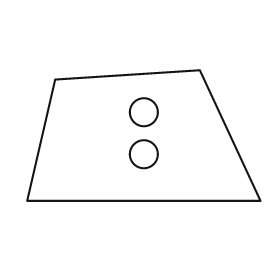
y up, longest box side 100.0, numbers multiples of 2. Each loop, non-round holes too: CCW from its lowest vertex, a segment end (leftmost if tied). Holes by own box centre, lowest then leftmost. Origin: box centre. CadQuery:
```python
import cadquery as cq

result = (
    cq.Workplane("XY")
    .moveTo(-50.0, -28.0)
    .lineTo(50.0, -28.0)
    .lineTo(24.0, 28.0)
    .lineTo(-38.0, 24.0)
    .close()
    .moveTo(0.0, -8.0)
    .circle(6.0)
    .moveTo(0.0, 10.0)
    .circle(6.0)
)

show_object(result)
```